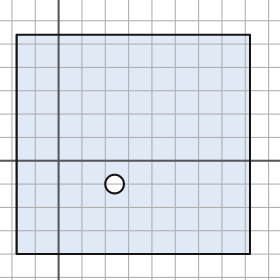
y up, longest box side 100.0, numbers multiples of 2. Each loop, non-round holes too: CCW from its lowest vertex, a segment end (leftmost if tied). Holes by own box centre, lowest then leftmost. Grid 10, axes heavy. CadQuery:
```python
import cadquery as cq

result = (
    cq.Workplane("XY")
    .moveTo(-18.0, -40.0)
    .lineTo(82.0, -40.0)
    .lineTo(82.0, 54.0)
    .lineTo(-18.0, 54.0)
    .close()
    .moveTo(24.0, -10.0)
    .circle(4.0)
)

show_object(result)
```